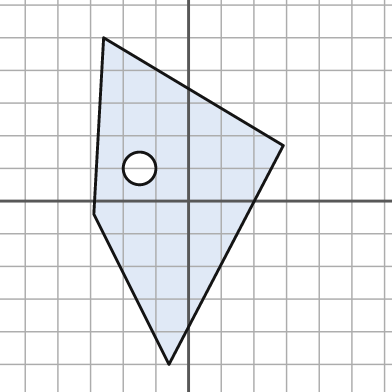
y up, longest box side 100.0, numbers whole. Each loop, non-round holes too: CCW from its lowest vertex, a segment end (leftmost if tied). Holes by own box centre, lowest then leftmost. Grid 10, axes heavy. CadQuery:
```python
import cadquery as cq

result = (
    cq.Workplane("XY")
    .moveTo(-6.0, -50.0)
    .lineTo(29.0, 17.0)
    .lineTo(-26.0, 50.0)
    .lineTo(-29.0, -4.0)
    .close()
    .moveTo(-15.0, 10.0)
    .circle(5.0)
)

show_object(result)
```